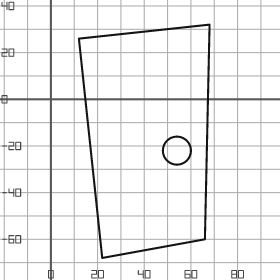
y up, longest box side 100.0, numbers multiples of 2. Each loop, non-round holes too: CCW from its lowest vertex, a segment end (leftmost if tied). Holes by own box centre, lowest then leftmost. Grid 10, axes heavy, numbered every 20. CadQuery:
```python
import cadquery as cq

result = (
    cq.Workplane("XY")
    .moveTo(22.0, -68.0)
    .lineTo(66.0, -60.0)
    .lineTo(68.0, 32.0)
    .lineTo(12.0, 26.0)
    .close()
    .moveTo(54.0, -22.0)
    .circle(6.0)
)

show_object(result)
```